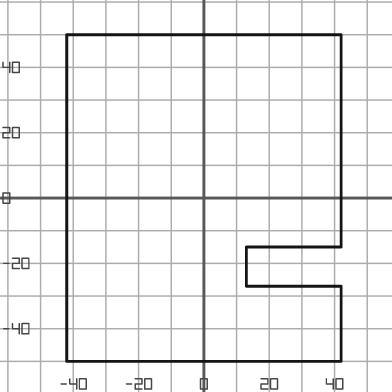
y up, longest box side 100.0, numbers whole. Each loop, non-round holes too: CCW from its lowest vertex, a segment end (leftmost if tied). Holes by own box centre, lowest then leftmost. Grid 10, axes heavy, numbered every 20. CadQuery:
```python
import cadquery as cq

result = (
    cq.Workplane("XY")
    .moveTo(-42.0, -50.0)
    .lineTo(42.0, -50.0)
    .lineTo(42.0, -27.0)
    .lineTo(13.0, -27.0)
    .lineTo(13.0, -15.0)
    .lineTo(42.0, -15.0)
    .lineTo(42.0, 50.0)
    .lineTo(-42.0, 50.0)
    .close()
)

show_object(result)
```